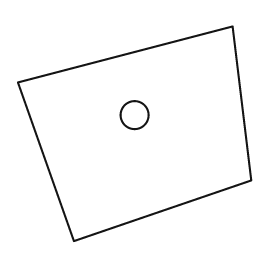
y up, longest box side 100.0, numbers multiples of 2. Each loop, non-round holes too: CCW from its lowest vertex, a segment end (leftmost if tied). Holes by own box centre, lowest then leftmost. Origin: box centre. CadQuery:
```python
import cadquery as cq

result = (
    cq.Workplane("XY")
    .moveTo(-26.0, -46.0)
    .lineTo(50.0, -20.0)
    .lineTo(42.0, 46.0)
    .lineTo(-50.0, 22.0)
    .close()
    .moveTo(0.0, 8.0)
    .circle(6.0)
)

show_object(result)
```